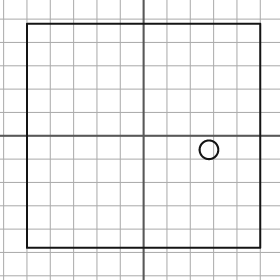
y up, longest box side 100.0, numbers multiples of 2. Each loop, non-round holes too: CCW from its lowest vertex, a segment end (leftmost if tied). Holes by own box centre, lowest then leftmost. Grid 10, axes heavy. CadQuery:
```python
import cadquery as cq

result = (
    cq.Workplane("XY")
    .moveTo(-50.0, -48.0)
    .lineTo(50.0, -48.0)
    .lineTo(50.0, 48.0)
    .lineTo(-50.0, 48.0)
    .close()
    .moveTo(28.0, -6.0)
    .circle(4.0)
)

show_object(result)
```